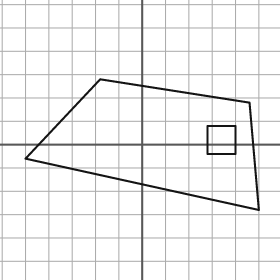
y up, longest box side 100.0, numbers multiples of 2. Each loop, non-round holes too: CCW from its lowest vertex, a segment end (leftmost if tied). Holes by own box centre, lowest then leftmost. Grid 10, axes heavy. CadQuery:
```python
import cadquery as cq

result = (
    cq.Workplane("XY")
    .moveTo(50.0, -28.0)
    .lineTo(46.0, 18.0)
    .lineTo(-18.0, 28.0)
    .lineTo(-50.0, -6.0)
    .close()
    .moveTo(28.0, -4.0)
    .lineTo(40.0, -4.0)
    .lineTo(40.0, 8.0)
    .lineTo(28.0, 8.0)
    .close()
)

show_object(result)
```